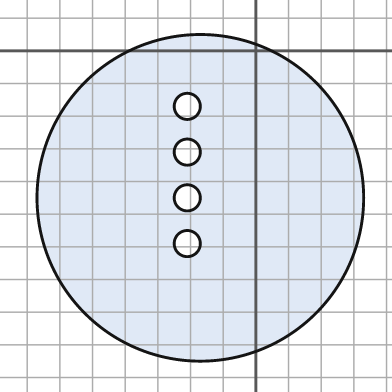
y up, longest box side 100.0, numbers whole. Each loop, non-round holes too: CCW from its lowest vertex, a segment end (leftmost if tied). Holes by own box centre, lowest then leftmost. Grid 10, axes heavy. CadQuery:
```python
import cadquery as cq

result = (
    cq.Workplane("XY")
    .moveTo(-17.0, -45.0)
    .circle(50.0)
    .moveTo(-21.0, -59.0)
    .circle(4.0)
    .moveTo(-21.0, -45.0)
    .circle(4.0)
    .moveTo(-21.0, -31.0)
    .circle(4.0)
    .moveTo(-21.0, -17.0)
    .circle(4.0)
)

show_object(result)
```